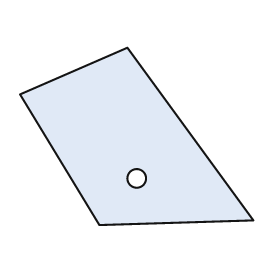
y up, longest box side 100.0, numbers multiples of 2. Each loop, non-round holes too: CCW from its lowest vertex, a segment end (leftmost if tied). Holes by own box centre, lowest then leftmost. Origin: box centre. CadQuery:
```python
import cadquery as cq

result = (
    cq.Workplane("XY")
    .moveTo(-16.0, -38.0)
    .lineTo(50.0, -36.0)
    .lineTo(-4.0, 38.0)
    .lineTo(-50.0, 18.0)
    .close()
    .moveTo(0.0, -18.0)
    .circle(4.0)
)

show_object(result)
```